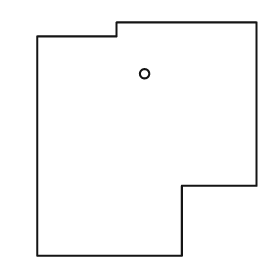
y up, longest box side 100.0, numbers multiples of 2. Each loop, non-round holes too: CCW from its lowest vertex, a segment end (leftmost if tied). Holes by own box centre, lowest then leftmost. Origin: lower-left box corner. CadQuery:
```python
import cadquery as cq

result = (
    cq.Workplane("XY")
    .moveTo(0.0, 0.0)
    .lineTo(62.0, 0.0)
    .lineTo(62.0, 30.0)
    .lineTo(94.0, 30.0)
    .lineTo(94.0, 100.0)
    .lineTo(34.0, 100.0)
    .lineTo(34.0, 94.0)
    .lineTo(0.0, 94.0)
    .close()
    .moveTo(46.0, 78.0)
    .circle(2.0)
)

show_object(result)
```